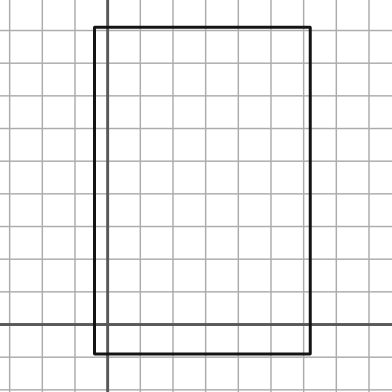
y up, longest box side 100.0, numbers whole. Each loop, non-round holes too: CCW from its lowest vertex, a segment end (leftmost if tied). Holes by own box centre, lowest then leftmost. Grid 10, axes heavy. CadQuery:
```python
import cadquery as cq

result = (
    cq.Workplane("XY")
    .moveTo(-4.0, -9.0)
    .lineTo(62.0, -9.0)
    .lineTo(62.0, 91.0)
    .lineTo(-4.0, 91.0)
    .close()
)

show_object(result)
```